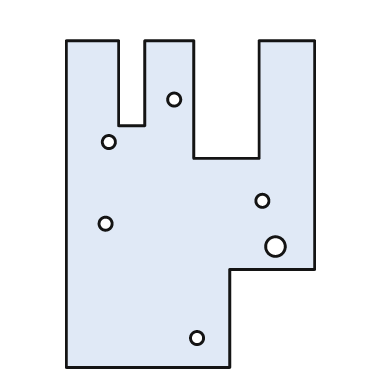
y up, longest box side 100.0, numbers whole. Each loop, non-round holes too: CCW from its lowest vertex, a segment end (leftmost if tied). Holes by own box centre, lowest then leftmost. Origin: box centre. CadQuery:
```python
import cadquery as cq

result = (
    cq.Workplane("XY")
    .moveTo(-38.0, -50.0)
    .lineTo(12.0, -50.0)
    .lineTo(12.0, -20.0)
    .lineTo(38.0, -20.0)
    .lineTo(38.0, 50.0)
    .lineTo(21.0, 50.0)
    .lineTo(21.0, 14.0)
    .lineTo(1.0, 14.0)
    .lineTo(1.0, 50.0)
    .lineTo(-14.0, 50.0)
    .lineTo(-14.0, 24.0)
    .lineTo(-22.0, 24.0)
    .lineTo(-22.0, 50.0)
    .lineTo(-38.0, 50.0)
    .close()
    .moveTo(2.0, -41.0)
    .circle(2.0)
    .moveTo(26.0, -13.0)
    .circle(3.0)
    .moveTo(-26.0, -6.0)
    .circle(2.0)
    .moveTo(22.0, 1.0)
    .circle(2.0)
    .moveTo(-25.0, 19.0)
    .circle(2.0)
    .moveTo(-5.0, 32.0)
    .circle(2.0)
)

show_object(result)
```